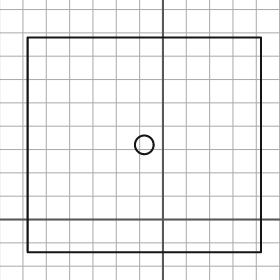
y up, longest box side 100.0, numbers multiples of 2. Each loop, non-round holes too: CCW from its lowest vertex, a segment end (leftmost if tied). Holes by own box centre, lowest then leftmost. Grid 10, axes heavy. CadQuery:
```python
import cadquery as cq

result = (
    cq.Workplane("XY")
    .moveTo(-58.0, -14.0)
    .lineTo(42.0, -14.0)
    .lineTo(42.0, 78.0)
    .lineTo(-58.0, 78.0)
    .close()
    .moveTo(-8.0, 32.0)
    .circle(4.0)
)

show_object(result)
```